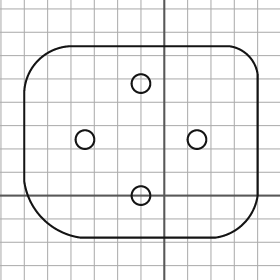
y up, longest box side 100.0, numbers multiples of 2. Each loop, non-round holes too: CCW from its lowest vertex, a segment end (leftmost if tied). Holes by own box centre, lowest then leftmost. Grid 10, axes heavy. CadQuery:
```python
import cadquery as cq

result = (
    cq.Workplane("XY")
    .moveTo(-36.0, -18.0)
    .lineTo(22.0, -18.0)
    .threePointArc((34.0, -12.0), (40.0, 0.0))
    .lineTo(40.0, 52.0)
    .threePointArc((36.0, 60.0), (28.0, 64.0))
    .lineTo(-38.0, 64.0)
    .threePointArc((-54.0, 58.0), (-60.0, 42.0))
    .lineTo(-60.0, 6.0)
    .threePointArc((-52.0, -10.0), (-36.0, -18.0))
    .close()
    .moveTo(-10.0, 0.0)
    .circle(4.0)
    .moveTo(-34.0, 24.0)
    .circle(4.0)
    .moveTo(14.0, 24.0)
    .circle(4.0)
    .moveTo(-10.0, 48.0)
    .circle(4.0)
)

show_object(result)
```